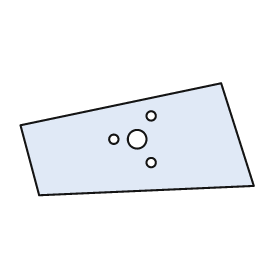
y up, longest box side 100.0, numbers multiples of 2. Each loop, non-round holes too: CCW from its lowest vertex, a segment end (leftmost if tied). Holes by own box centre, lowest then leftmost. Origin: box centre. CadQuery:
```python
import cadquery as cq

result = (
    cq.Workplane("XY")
    .moveTo(-42.0, -24.0)
    .lineTo(50.0, -20.0)
    .lineTo(36.0, 24.0)
    .lineTo(-50.0, 6.0)
    .close()
    .moveTo(6.0, -10.0)
    .circle(2.0)
    .moveTo(-10.0, 0.0)
    .circle(2.0)
    .moveTo(0.0, 0.0)
    .circle(4.0)
    .moveTo(6.0, 10.0)
    .circle(2.0)
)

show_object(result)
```